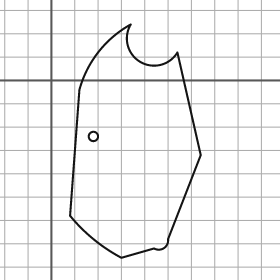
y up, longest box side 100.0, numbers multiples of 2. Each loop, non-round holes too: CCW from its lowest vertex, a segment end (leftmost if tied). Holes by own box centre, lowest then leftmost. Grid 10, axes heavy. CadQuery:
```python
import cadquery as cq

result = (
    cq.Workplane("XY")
    .moveTo(30.0, -76.0)
    .lineTo(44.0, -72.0)
    .threePointArc((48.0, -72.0), (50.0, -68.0))
    .lineTo(64.0, -32.0)
    .lineTo(54.0, 12.0)
    .threePointArc((38.0, 8.0), (34.0, 24.0))
    .threePointArc((20.0, 12.0), (12.0, -4.0))
    .lineTo(8.0, -58.0)
    .threePointArc((18.0, -68.0), (30.0, -76.0))
    .close()
    .moveTo(18.0, -24.0)
    .circle(2.0)
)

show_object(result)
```